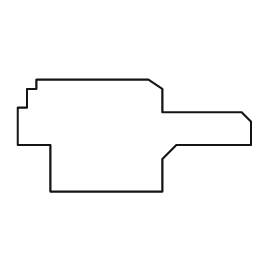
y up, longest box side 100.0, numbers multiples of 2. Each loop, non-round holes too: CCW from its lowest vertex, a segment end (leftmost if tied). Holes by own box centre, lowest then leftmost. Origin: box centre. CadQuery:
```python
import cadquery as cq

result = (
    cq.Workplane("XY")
    .moveTo(-36.0, -24.0)
    .lineTo(12.0, -24.0)
    .lineTo(12.0, -10.0)
    .lineTo(18.0, -4.0)
    .lineTo(50.0, -4.0)
    .lineTo(50.0, 6.0)
    .lineTo(46.0, 10.0)
    .lineTo(12.0, 10.0)
    .lineTo(12.0, 20.0)
    .lineTo(6.0, 24.0)
    .lineTo(-42.0, 24.0)
    .lineTo(-42.0, 20.0)
    .lineTo(-46.0, 20.0)
    .lineTo(-46.0, 12.0)
    .lineTo(-50.0, 12.0)
    .lineTo(-50.0, -4.0)
    .lineTo(-36.0, -4.0)
    .close()
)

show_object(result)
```